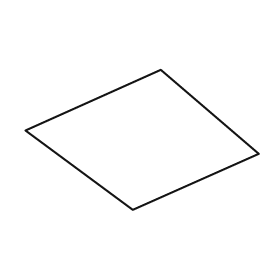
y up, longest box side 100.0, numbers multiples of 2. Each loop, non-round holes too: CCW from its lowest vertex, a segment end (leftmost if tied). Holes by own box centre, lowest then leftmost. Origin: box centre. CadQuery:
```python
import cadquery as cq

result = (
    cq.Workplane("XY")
    .moveTo(-4.0, -30.0)
    .lineTo(50.0, -6.0)
    .lineTo(8.0, 30.0)
    .lineTo(-50.0, 4.0)
    .close()
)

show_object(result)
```